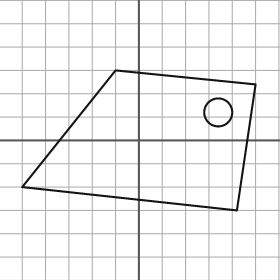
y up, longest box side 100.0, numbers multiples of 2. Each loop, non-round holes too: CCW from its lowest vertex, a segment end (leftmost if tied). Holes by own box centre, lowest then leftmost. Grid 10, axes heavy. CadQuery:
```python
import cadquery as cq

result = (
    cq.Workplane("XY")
    .moveTo(42.0, -30.0)
    .lineTo(50.0, 24.0)
    .lineTo(-10.0, 30.0)
    .lineTo(-50.0, -20.0)
    .close()
    .moveTo(34.0, 12.0)
    .circle(6.0)
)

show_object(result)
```